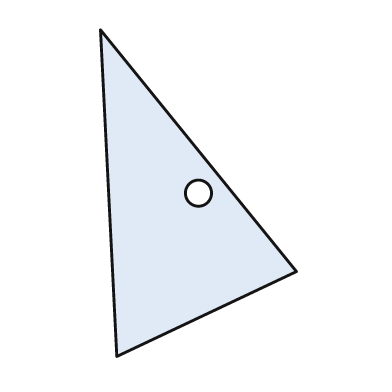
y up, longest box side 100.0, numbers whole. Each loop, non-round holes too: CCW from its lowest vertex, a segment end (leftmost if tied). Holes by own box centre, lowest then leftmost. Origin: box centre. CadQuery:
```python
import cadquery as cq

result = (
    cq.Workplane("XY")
    .moveTo(-25.0, -50.0)
    .lineTo(30.0, -24.0)
    .lineTo(-30.0, 50.0)
    .close()
    .moveTo(0.0, 0.0)
    .circle(4.0)
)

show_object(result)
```